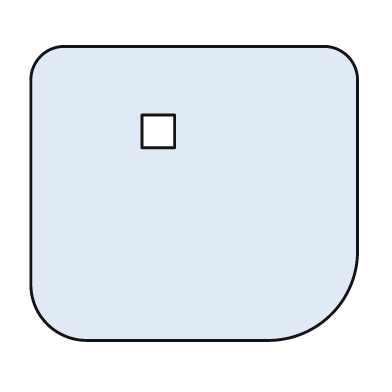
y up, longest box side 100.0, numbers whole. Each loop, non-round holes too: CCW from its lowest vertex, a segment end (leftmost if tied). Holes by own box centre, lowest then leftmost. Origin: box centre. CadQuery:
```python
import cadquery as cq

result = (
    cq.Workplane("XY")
    .moveTo(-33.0, -45.0)
    .lineTo(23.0, -45.0)
    .threePointArc((42.0, -37.0), (50.0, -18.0))
    .lineTo(50.0, 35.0)
    .threePointArc((47.0, 42.0), (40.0, 45.0))
    .lineTo(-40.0, 45.0)
    .threePointArc((-47.0, 42.0), (-50.0, 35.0))
    .lineTo(-50.0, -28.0)
    .threePointArc((-45.0, -40.0), (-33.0, -45.0))
    .close()
    .moveTo(-16.0, 14.0)
    .lineTo(-6.0, 14.0)
    .lineTo(-6.0, 24.0)
    .lineTo(-16.0, 24.0)
    .close()
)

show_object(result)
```